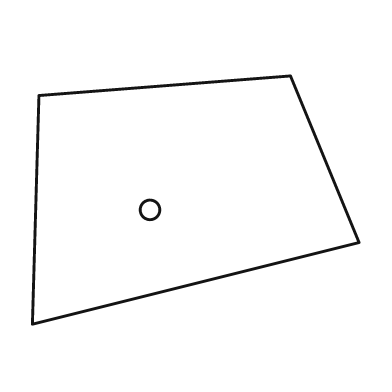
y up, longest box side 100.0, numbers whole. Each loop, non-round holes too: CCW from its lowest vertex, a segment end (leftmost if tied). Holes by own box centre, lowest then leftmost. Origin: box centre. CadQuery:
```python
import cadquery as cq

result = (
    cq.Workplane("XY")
    .moveTo(-50.0, -38.0)
    .lineTo(50.0, -13.0)
    .lineTo(29.0, 38.0)
    .lineTo(-48.0, 32.0)
    .close()
    .moveTo(-14.0, -3.0)
    .circle(3.0)
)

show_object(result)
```